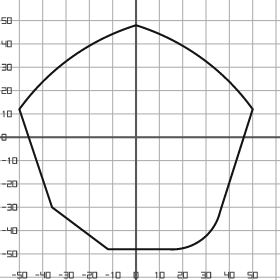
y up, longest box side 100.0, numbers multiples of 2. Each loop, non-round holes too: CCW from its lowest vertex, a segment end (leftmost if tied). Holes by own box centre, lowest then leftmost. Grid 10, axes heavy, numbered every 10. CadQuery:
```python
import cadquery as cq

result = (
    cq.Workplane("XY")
    .moveTo(-12.0, -48.0)
    .lineTo(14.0, -48.0)
    .threePointArc((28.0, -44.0), (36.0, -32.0))
    .lineTo(50.0, 12.0)
    .threePointArc((28.0, 34.0), (0.0, 48.0))
    .threePointArc((-28.0, 34.0), (-50.0, 12.0))
    .lineTo(-36.0, -30.0)
    .close()
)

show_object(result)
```